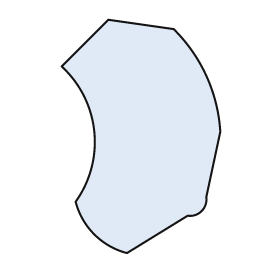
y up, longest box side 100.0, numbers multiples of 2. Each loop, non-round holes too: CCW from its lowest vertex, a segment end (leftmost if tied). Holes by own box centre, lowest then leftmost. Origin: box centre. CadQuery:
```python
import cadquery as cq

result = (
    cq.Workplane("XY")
    .moveTo(-6.0, -50.0)
    .lineTo(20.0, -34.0)
    .threePointArc((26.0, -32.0), (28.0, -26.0))
    .lineTo(34.0, 2.0)
    .threePointArc((28.0, 26.0), (14.0, 46.0))
    .lineTo(-14.0, 50.0)
    .lineTo(-34.0, 30.0)
    .threePointArc((-20.0, 2.0), (-28.0, -28.0))
    .threePointArc((-20.0, -42.0), (-6.0, -50.0))
    .close()
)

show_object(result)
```